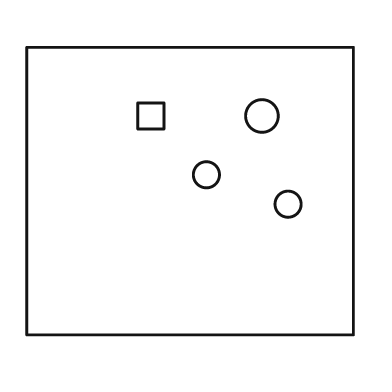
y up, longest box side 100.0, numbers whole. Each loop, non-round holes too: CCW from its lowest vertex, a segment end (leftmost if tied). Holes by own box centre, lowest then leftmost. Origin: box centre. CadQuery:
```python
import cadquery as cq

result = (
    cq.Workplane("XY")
    .moveTo(-50.0, -44.0)
    .lineTo(50.0, -44.0)
    .lineTo(50.0, 44.0)
    .lineTo(-50.0, 44.0)
    .close()
    .moveTo(30.0, -4.0)
    .circle(4.0)
    .moveTo(5.0, 5.0)
    .circle(4.0)
    .moveTo(-16.0, 19.0)
    .lineTo(-8.0, 19.0)
    .lineTo(-8.0, 27.0)
    .lineTo(-16.0, 27.0)
    .close()
    .moveTo(22.0, 23.0)
    .circle(5.0)
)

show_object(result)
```